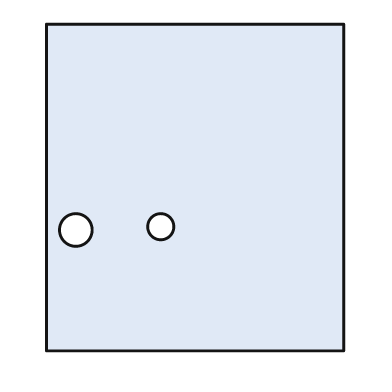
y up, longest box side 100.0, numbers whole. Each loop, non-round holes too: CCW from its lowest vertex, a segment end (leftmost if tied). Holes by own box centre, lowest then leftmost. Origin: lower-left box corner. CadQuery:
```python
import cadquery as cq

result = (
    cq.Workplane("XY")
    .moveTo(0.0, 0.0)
    .lineTo(91.0, 0.0)
    .lineTo(91.0, 100.0)
    .lineTo(0.0, 100.0)
    .close()
    .moveTo(9.0, 37.0)
    .circle(5.0)
    .moveTo(35.0, 38.0)
    .circle(4.0)
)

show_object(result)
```